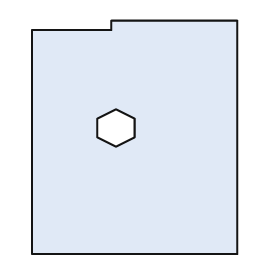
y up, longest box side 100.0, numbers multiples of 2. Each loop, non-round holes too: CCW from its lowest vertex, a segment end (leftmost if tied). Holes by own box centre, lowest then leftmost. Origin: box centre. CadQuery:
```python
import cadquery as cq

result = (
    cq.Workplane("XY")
    .moveTo(-44.0, -50.0)
    .lineTo(44.0, -50.0)
    .lineTo(44.0, 50.0)
    .lineTo(-10.0, 50.0)
    .lineTo(-10.0, 46.0)
    .lineTo(-44.0, 46.0)
    .close()
    .moveTo(-8.0, -4.0)
    .lineTo(0.0, 0.0)
    .lineTo(0.0, 8.0)
    .lineTo(-8.0, 12.0)
    .lineTo(-16.0, 8.0)
    .lineTo(-16.0, 0.0)
    .close()
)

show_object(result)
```